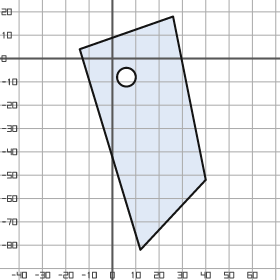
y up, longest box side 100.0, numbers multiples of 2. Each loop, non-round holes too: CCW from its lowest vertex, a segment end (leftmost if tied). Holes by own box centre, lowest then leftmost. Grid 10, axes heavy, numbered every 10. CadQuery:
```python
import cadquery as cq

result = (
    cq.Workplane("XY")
    .moveTo(12.0, -82.0)
    .lineTo(40.0, -52.0)
    .lineTo(26.0, 18.0)
    .lineTo(-14.0, 4.0)
    .close()
    .moveTo(6.0, -8.0)
    .circle(4.0)
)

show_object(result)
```